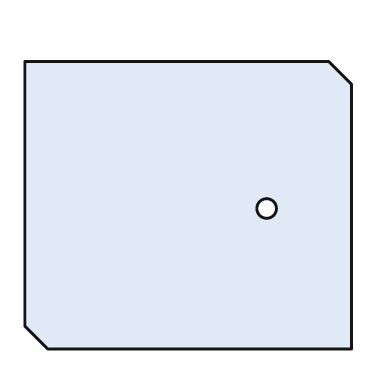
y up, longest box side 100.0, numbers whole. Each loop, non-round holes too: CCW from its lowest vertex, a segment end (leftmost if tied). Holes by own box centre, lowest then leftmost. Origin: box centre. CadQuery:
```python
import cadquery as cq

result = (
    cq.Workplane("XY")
    .moveTo(-43.0, -44.0)
    .lineTo(50.0, -44.0)
    .lineTo(50.0, 37.0)
    .lineTo(43.0, 44.0)
    .lineTo(-50.0, 44.0)
    .lineTo(-50.0, -37.0)
    .close()
    .moveTo(24.0, -1.0)
    .circle(3.0)
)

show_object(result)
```